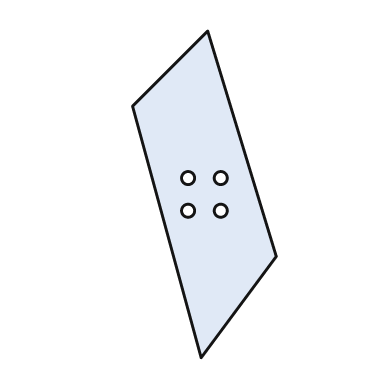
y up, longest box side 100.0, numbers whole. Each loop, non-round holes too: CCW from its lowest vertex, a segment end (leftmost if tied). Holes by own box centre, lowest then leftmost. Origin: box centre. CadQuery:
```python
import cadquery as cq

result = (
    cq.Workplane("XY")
    .moveTo(-1.0, -50.0)
    .lineTo(22.0, -19.0)
    .lineTo(1.0, 50.0)
    .lineTo(-22.0, 27.0)
    .close()
    .moveTo(-5.0, -5.0)
    .circle(2.0)
    .moveTo(5.0, -5.0)
    .circle(2.0)
    .moveTo(-5.0, 5.0)
    .circle(2.0)
    .moveTo(5.0, 5.0)
    .circle(2.0)
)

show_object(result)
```